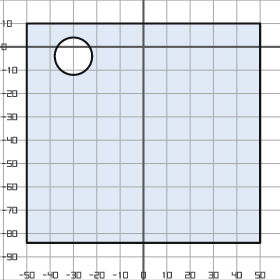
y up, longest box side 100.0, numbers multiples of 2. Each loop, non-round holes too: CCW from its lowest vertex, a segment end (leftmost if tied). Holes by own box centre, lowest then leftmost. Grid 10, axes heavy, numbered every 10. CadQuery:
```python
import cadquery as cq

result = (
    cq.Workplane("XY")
    .moveTo(-50.0, -84.0)
    .lineTo(50.0, -84.0)
    .lineTo(50.0, 10.0)
    .lineTo(-50.0, 10.0)
    .close()
    .moveTo(-30.0, -4.0)
    .circle(8.0)
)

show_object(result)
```